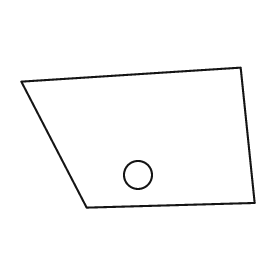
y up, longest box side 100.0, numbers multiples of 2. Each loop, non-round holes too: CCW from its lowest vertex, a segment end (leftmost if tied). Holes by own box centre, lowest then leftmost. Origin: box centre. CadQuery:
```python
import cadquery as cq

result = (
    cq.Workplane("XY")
    .moveTo(-22.0, -30.0)
    .lineTo(50.0, -28.0)
    .lineTo(44.0, 30.0)
    .lineTo(-50.0, 24.0)
    .close()
    .moveTo(0.0, -16.0)
    .circle(6.0)
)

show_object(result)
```